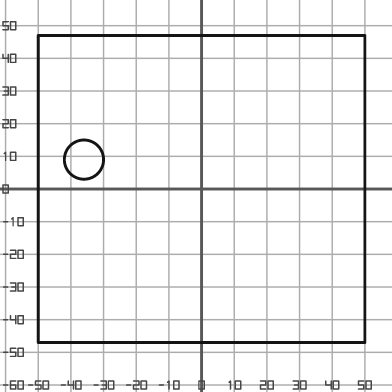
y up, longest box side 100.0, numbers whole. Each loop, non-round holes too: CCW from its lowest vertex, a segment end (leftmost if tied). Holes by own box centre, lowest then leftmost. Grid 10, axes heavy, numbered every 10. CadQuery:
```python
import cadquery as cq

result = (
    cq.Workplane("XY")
    .moveTo(-50.0, -47.0)
    .lineTo(50.0, -47.0)
    .lineTo(50.0, 47.0)
    .lineTo(-50.0, 47.0)
    .close()
    .moveTo(-36.0, 9.0)
    .circle(6.0)
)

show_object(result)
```